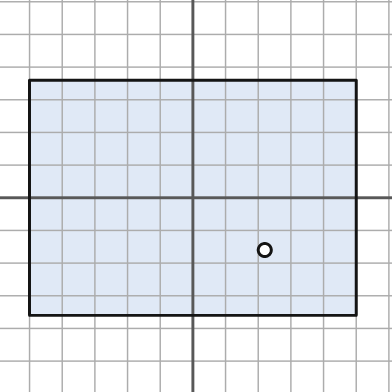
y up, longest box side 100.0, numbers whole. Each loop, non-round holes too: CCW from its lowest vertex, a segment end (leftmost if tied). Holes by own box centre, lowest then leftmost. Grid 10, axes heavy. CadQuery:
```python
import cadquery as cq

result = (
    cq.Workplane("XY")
    .moveTo(-50.0, -36.0)
    .lineTo(50.0, -36.0)
    .lineTo(50.0, 36.0)
    .lineTo(-50.0, 36.0)
    .close()
    .moveTo(22.0, -16.0)
    .circle(2.0)
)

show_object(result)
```